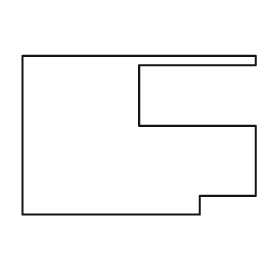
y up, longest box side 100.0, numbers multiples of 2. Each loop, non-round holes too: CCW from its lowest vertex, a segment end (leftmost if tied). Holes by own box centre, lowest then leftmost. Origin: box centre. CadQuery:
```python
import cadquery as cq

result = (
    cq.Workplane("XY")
    .moveTo(-50.0, -34.0)
    .lineTo(26.0, -34.0)
    .lineTo(26.0, -26.0)
    .lineTo(50.0, -26.0)
    .lineTo(50.0, 4.0)
    .lineTo(0.0, 4.0)
    .lineTo(0.0, 30.0)
    .lineTo(50.0, 30.0)
    .lineTo(50.0, 34.0)
    .lineTo(-50.0, 34.0)
    .close()
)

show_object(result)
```